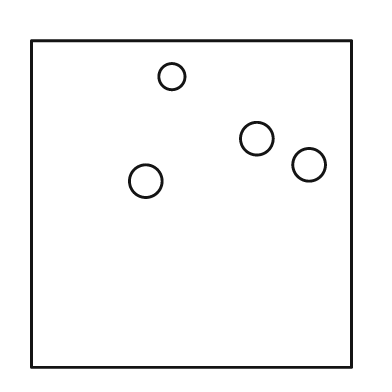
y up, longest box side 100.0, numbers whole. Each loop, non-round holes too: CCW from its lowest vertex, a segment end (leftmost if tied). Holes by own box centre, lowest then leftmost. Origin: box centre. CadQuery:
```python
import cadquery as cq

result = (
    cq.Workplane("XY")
    .moveTo(-49.0, -50.0)
    .lineTo(49.0, -50.0)
    .lineTo(49.0, 50.0)
    .lineTo(-49.0, 50.0)
    .close()
    .moveTo(-14.0, 7.0)
    .circle(5.0)
    .moveTo(36.0, 12.0)
    .circle(5.0)
    .moveTo(20.0, 20.0)
    .circle(5.0)
    .moveTo(-6.0, 39.0)
    .circle(4.0)
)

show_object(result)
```